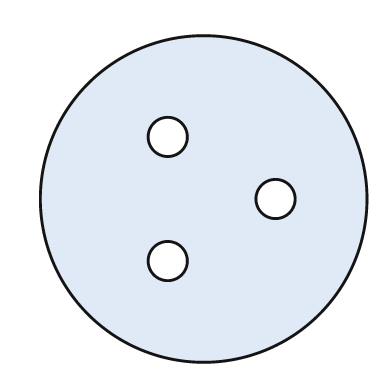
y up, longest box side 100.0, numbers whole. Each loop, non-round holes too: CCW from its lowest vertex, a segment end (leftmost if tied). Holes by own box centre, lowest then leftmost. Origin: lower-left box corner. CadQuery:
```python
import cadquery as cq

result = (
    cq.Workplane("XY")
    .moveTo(50.0, 50.0)
    .circle(50.0)
    .moveTo(39.0, 31.0)
    .circle(6.0)
    .moveTo(72.0, 50.0)
    .circle(6.0)
    .moveTo(39.0, 69.0)
    .circle(6.0)
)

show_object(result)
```